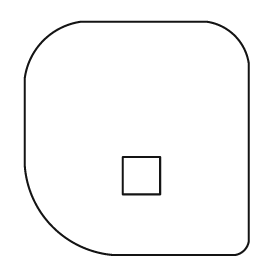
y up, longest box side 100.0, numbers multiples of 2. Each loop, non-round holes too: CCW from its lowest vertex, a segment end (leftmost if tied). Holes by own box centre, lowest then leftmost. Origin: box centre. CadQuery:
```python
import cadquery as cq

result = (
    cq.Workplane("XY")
    .moveTo(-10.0, -50.0)
    .lineTo(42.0, -50.0)
    .threePointArc((46.0, -48.0), (48.0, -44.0))
    .lineTo(48.0, 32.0)
    .threePointArc((42.0, 44.0), (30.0, 50.0))
    .lineTo(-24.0, 50.0)
    .threePointArc((-40.0, 42.0), (-48.0, 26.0))
    .lineTo(-48.0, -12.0)
    .threePointArc((-36.0, -38.0), (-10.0, -50.0))
    .close()
    .moveTo(-6.0, -24.0)
    .lineTo(10.0, -24.0)
    .lineTo(10.0, -8.0)
    .lineTo(-6.0, -8.0)
    .close()
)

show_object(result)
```